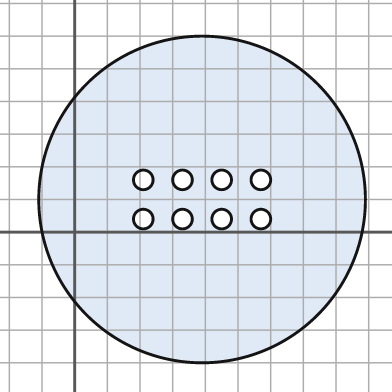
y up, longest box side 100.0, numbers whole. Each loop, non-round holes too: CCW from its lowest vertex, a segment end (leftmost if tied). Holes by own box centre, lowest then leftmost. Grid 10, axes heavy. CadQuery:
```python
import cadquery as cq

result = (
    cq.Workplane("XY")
    .moveTo(39.0, 10.0)
    .circle(50.0)
    .moveTo(21.0, 4.0)
    .circle(3.0)
    .moveTo(33.0, 4.0)
    .circle(3.0)
    .moveTo(45.0, 4.0)
    .circle(3.0)
    .moveTo(57.0, 4.0)
    .circle(3.0)
    .moveTo(21.0, 16.0)
    .circle(3.0)
    .moveTo(33.0, 16.0)
    .circle(3.0)
    .moveTo(45.0, 16.0)
    .circle(3.0)
    .moveTo(57.0, 16.0)
    .circle(3.0)
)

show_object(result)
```